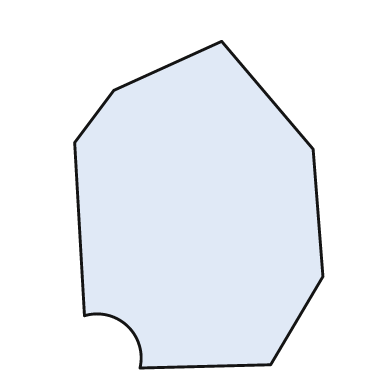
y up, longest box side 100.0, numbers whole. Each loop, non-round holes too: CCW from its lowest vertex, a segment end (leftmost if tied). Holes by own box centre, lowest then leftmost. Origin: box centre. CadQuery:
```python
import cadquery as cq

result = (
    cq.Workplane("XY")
    .moveTo(-18.0, -50.0)
    .lineTo(22.0, -49.0)
    .lineTo(38.0, -22.0)
    .lineTo(35.0, 17.0)
    .lineTo(7.0, 50.0)
    .lineTo(-26.0, 35.0)
    .lineTo(-38.0, 19.0)
    .lineTo(-35.0, -34.0)
    .threePointArc((-22.0, -37.0), (-18.0, -50.0))
    .close()
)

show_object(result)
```